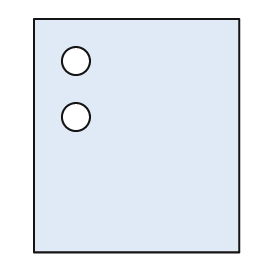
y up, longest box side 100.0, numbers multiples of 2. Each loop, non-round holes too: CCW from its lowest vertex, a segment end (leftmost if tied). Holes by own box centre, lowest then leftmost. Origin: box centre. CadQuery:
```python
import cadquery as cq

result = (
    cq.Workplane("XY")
    .moveTo(-44.0, -50.0)
    .lineTo(44.0, -50.0)
    .lineTo(44.0, 50.0)
    .lineTo(-44.0, 50.0)
    .close()
    .moveTo(-26.0, 8.0)
    .circle(6.0)
    .moveTo(-26.0, 32.0)
    .circle(6.0)
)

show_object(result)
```